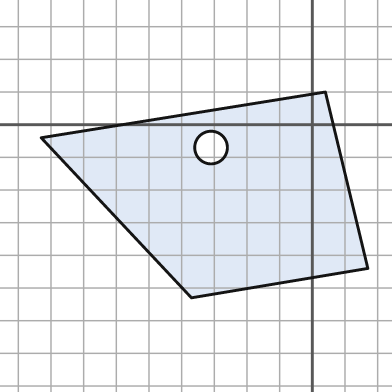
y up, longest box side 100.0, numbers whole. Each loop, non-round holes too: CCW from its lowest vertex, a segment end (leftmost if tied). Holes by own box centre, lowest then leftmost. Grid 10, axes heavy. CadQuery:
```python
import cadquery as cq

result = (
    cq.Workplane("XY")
    .moveTo(-37.0, -53.0)
    .lineTo(17.0, -44.0)
    .lineTo(4.0, 10.0)
    .lineTo(-83.0, -4.0)
    .close()
    .moveTo(-31.0, -7.0)
    .circle(5.0)
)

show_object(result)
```